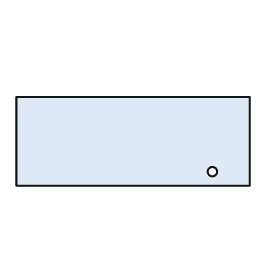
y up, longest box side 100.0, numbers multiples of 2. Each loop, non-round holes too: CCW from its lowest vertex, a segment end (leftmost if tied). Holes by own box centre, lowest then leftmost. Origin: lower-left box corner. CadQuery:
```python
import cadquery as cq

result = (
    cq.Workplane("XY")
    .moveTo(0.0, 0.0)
    .lineTo(100.0, 0.0)
    .lineTo(100.0, 38.0)
    .lineTo(0.0, 38.0)
    .close()
    .moveTo(84.0, 6.0)
    .circle(2.0)
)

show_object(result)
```